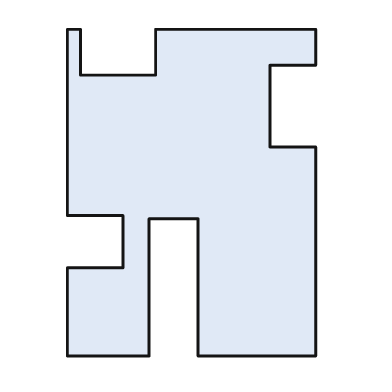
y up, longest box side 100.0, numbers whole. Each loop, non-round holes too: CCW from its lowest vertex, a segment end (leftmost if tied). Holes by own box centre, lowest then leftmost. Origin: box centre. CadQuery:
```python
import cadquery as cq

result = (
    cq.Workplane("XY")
    .moveTo(-38.0, -50.0)
    .lineTo(-13.0, -50.0)
    .lineTo(-13.0, -8.0)
    .lineTo(2.0, -8.0)
    .lineTo(2.0, -50.0)
    .lineTo(38.0, -50.0)
    .lineTo(38.0, 14.0)
    .lineTo(24.0, 14.0)
    .lineTo(24.0, 39.0)
    .lineTo(38.0, 39.0)
    .lineTo(38.0, 50.0)
    .lineTo(-11.0, 50.0)
    .lineTo(-11.0, 36.0)
    .lineTo(-34.0, 36.0)
    .lineTo(-34.0, 50.0)
    .lineTo(-38.0, 50.0)
    .lineTo(-38.0, -7.0)
    .lineTo(-21.0, -7.0)
    .lineTo(-21.0, -23.0)
    .lineTo(-38.0, -23.0)
    .close()
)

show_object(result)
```